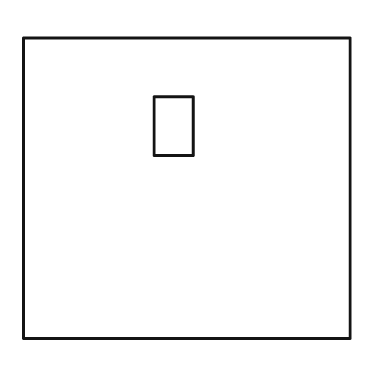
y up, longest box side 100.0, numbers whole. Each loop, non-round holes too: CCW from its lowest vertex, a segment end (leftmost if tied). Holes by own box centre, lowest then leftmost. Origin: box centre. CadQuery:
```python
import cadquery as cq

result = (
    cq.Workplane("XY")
    .moveTo(-50.0, -46.0)
    .lineTo(50.0, -46.0)
    .lineTo(50.0, 46.0)
    .lineTo(-50.0, 46.0)
    .close()
    .moveTo(-10.0, 10.0)
    .lineTo(2.0, 10.0)
    .lineTo(2.0, 28.0)
    .lineTo(-10.0, 28.0)
    .close()
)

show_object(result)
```